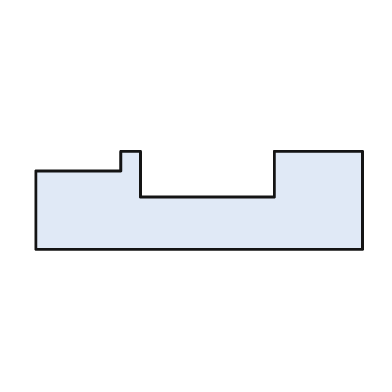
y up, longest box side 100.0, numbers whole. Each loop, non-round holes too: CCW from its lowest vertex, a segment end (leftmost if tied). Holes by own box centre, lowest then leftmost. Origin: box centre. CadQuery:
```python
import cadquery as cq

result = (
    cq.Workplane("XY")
    .moveTo(-50.0, -15.0)
    .lineTo(50.0, -15.0)
    .lineTo(50.0, 15.0)
    .lineTo(23.0, 15.0)
    .lineTo(23.0, 1.0)
    .lineTo(-18.0, 1.0)
    .lineTo(-18.0, 15.0)
    .lineTo(-24.0, 15.0)
    .lineTo(-24.0, 9.0)
    .lineTo(-50.0, 9.0)
    .close()
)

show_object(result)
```